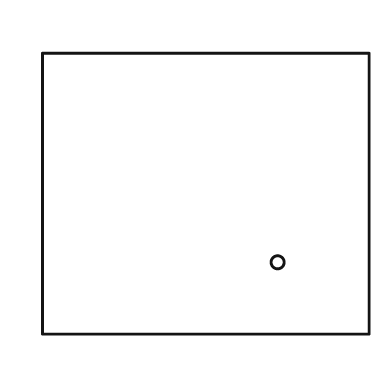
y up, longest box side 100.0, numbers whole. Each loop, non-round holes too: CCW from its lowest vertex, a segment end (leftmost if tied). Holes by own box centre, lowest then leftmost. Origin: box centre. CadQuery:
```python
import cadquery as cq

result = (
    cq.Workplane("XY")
    .moveTo(-50.0, -43.0)
    .lineTo(50.0, -43.0)
    .lineTo(50.0, 43.0)
    .lineTo(-50.0, 43.0)
    .close()
    .moveTo(22.0, -21.0)
    .circle(2.0)
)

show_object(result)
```